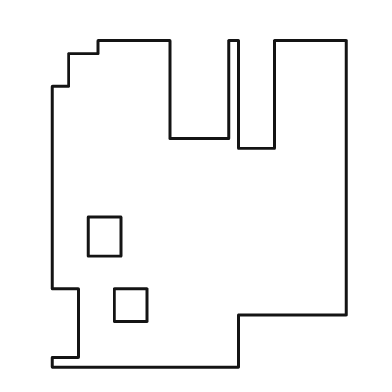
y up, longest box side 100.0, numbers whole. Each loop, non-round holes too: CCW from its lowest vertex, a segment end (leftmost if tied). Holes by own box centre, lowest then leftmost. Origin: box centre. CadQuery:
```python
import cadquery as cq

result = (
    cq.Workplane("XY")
    .moveTo(-45.0, -50.0)
    .lineTo(12.0, -50.0)
    .lineTo(12.0, -34.0)
    .lineTo(45.0, -34.0)
    .lineTo(45.0, 50.0)
    .lineTo(23.0, 50.0)
    .lineTo(23.0, 17.0)
    .lineTo(12.0, 17.0)
    .lineTo(12.0, 50.0)
    .lineTo(9.0, 50.0)
    .lineTo(9.0, 20.0)
    .lineTo(-9.0, 20.0)
    .lineTo(-9.0, 50.0)
    .lineTo(-31.0, 50.0)
    .lineTo(-31.0, 46.0)
    .lineTo(-40.0, 46.0)
    .lineTo(-40.0, 36.0)
    .lineTo(-45.0, 36.0)
    .lineTo(-45.0, -26.0)
    .lineTo(-37.0, -26.0)
    .lineTo(-37.0, -47.0)
    .lineTo(-45.0, -47.0)
    .close()
    .moveTo(-26.0, -36.0)
    .lineTo(-16.0, -36.0)
    .lineTo(-16.0, -26.0)
    .lineTo(-26.0, -26.0)
    .close()
    .moveTo(-34.0, -16.0)
    .lineTo(-24.0, -16.0)
    .lineTo(-24.0, -4.0)
    .lineTo(-34.0, -4.0)
    .close()
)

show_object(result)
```